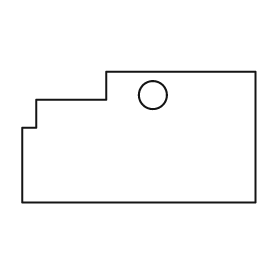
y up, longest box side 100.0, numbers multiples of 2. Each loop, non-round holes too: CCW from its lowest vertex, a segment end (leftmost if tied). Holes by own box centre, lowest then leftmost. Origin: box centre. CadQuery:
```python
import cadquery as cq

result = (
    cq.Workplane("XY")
    .moveTo(-50.0, -28.0)
    .lineTo(50.0, -28.0)
    .lineTo(50.0, 28.0)
    .lineTo(-14.0, 28.0)
    .lineTo(-14.0, 16.0)
    .lineTo(-44.0, 16.0)
    .lineTo(-44.0, 4.0)
    .lineTo(-50.0, 4.0)
    .close()
    .moveTo(6.0, 18.0)
    .circle(6.0)
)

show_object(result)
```